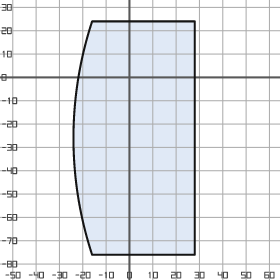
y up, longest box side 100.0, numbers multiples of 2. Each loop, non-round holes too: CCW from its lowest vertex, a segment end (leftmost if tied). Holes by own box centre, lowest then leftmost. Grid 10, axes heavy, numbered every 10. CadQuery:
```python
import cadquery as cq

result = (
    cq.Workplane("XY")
    .moveTo(-16.0, -76.0)
    .lineTo(28.0, -76.0)
    .lineTo(28.0, 24.0)
    .lineTo(-16.0, 24.0)
    .threePointArc((-24.0, -26.0), (-16.0, -76.0))
    .close()
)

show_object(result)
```